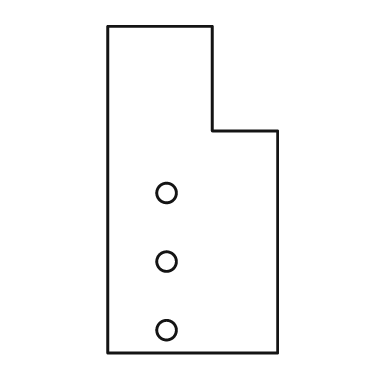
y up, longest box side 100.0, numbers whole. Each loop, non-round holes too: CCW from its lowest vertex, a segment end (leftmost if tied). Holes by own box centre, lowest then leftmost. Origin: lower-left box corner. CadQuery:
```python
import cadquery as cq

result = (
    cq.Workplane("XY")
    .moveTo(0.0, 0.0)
    .lineTo(52.0, 0.0)
    .lineTo(52.0, 68.0)
    .lineTo(32.0, 68.0)
    .lineTo(32.0, 100.0)
    .lineTo(0.0, 100.0)
    .close()
    .moveTo(18.0, 7.0)
    .circle(3.0)
    .moveTo(18.0, 28.0)
    .circle(3.0)
    .moveTo(18.0, 49.0)
    .circle(3.0)
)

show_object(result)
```